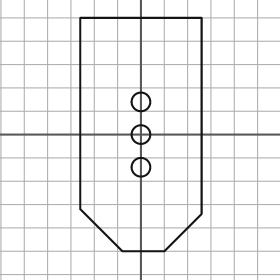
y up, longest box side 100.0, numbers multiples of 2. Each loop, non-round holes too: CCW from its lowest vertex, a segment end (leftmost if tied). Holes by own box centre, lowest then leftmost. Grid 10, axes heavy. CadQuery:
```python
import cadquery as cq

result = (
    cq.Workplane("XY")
    .moveTo(-8.0, -50.0)
    .lineTo(10.0, -50.0)
    .lineTo(26.0, -34.0)
    .lineTo(26.0, 50.0)
    .lineTo(-26.0, 50.0)
    .lineTo(-26.0, -32.0)
    .close()
    .moveTo(0.0, -14.0)
    .circle(4.0)
    .moveTo(0.0, 0.0)
    .circle(4.0)
    .moveTo(0.0, 14.0)
    .circle(4.0)
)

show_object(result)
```